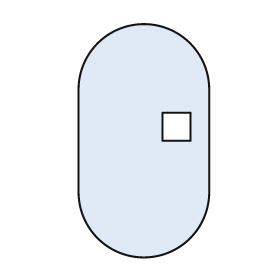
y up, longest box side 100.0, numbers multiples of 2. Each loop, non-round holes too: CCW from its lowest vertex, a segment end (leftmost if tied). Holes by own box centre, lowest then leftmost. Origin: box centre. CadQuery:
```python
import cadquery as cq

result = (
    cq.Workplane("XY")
    .moveTo(-28.0, -22.0)
    .threePointArc((0.0, -50.0), (28.0, -22.0))
    .lineTo(28.0, 22.0)
    .threePointArc((0.0, 50.0), (-28.0, 22.0))
    .close()
    .moveTo(8.0, 0.0)
    .lineTo(20.0, 0.0)
    .lineTo(20.0, 12.0)
    .lineTo(8.0, 12.0)
    .close()
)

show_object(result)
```